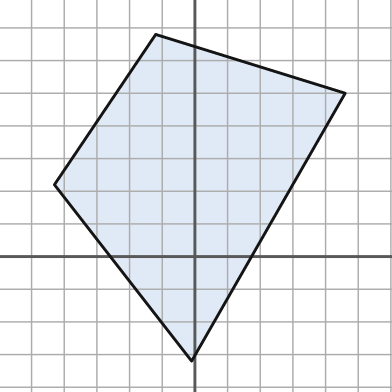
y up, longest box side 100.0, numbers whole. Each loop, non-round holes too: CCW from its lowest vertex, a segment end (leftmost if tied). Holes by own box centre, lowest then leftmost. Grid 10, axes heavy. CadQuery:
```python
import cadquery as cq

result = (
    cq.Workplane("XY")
    .moveTo(-1.0, -32.0)
    .lineTo(46.0, 50.0)
    .lineTo(-12.0, 68.0)
    .lineTo(-43.0, 22.0)
    .close()
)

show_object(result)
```